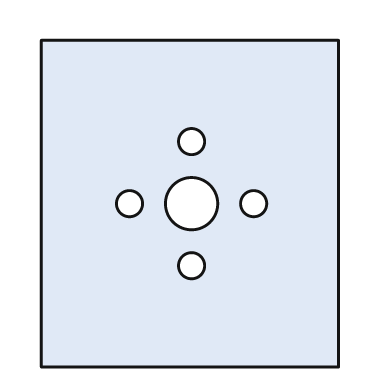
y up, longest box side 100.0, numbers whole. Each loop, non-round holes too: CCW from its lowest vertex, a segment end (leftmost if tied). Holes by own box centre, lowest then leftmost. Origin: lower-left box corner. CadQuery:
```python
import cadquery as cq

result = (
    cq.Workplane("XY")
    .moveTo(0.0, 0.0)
    .lineTo(91.0, 0.0)
    .lineTo(91.0, 100.0)
    .lineTo(0.0, 100.0)
    .close()
    .moveTo(46.0, 31.0)
    .circle(4.0)
    .moveTo(27.0, 50.0)
    .circle(4.0)
    .moveTo(46.0, 50.0)
    .circle(8.0)
    .moveTo(65.0, 50.0)
    .circle(4.0)
    .moveTo(46.0, 69.0)
    .circle(4.0)
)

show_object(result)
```